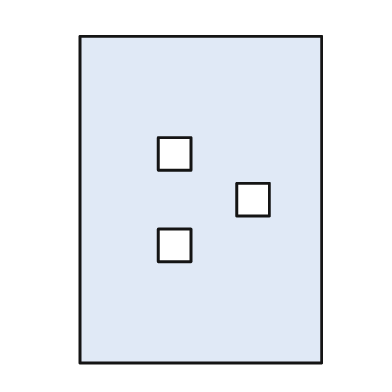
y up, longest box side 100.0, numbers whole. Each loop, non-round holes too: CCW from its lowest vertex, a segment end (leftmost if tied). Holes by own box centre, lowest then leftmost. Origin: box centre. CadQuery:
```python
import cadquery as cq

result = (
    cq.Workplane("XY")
    .moveTo(-37.0, -50.0)
    .lineTo(37.0, -50.0)
    .lineTo(37.0, 50.0)
    .lineTo(-37.0, 50.0)
    .close()
    .moveTo(-13.0, -19.0)
    .lineTo(-3.0, -19.0)
    .lineTo(-3.0, -9.0)
    .lineTo(-13.0, -9.0)
    .close()
    .moveTo(11.0, -5.0)
    .lineTo(21.0, -5.0)
    .lineTo(21.0, 5.0)
    .lineTo(11.0, 5.0)
    .close()
    .moveTo(-13.0, 9.0)
    .lineTo(-3.0, 9.0)
    .lineTo(-3.0, 19.0)
    .lineTo(-13.0, 19.0)
    .close()
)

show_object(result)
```